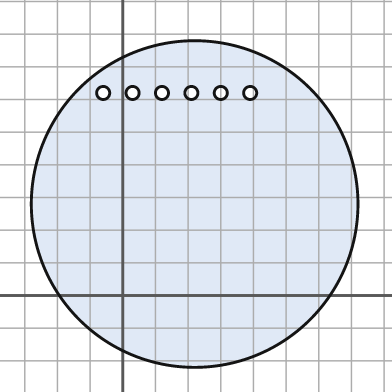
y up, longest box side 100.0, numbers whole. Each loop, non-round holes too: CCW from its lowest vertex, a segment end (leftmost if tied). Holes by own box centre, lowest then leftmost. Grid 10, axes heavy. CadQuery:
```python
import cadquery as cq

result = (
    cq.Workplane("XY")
    .moveTo(22.0, 28.0)
    .circle(50.0)
    .moveTo(-6.0, 62.0)
    .circle(2.0)
    .moveTo(3.0, 62.0)
    .circle(2.0)
    .moveTo(12.0, 62.0)
    .circle(2.0)
    .moveTo(21.0, 62.0)
    .circle(2.0)
    .moveTo(30.0, 62.0)
    .circle(2.0)
    .moveTo(39.0, 62.0)
    .circle(2.0)
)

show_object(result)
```